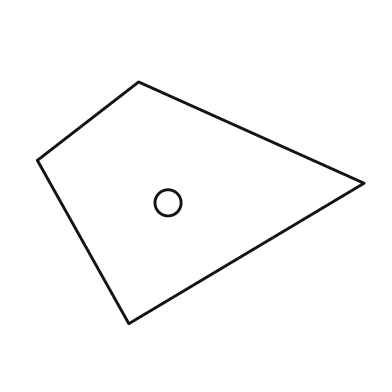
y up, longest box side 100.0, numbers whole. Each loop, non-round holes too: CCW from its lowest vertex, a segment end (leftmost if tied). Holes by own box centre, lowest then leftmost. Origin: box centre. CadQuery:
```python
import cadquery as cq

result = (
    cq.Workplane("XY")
    .moveTo(-22.0, -37.0)
    .lineTo(50.0, 6.0)
    .lineTo(-19.0, 37.0)
    .lineTo(-50.0, 13.0)
    .close()
    .moveTo(-10.0, 0.0)
    .circle(4.0)
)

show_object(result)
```